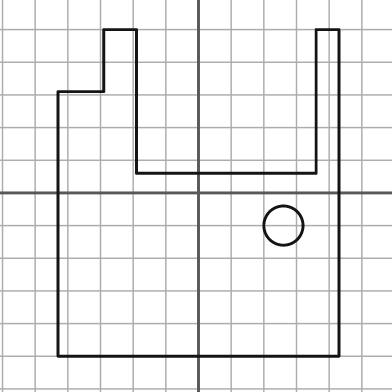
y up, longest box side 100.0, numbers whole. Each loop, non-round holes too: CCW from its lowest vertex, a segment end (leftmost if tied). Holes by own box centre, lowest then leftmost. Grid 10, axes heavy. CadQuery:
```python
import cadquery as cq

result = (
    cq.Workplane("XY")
    .moveTo(-43.0, -50.0)
    .lineTo(43.0, -50.0)
    .lineTo(43.0, 50.0)
    .lineTo(36.0, 50.0)
    .lineTo(36.0, 6.0)
    .lineTo(-19.0, 6.0)
    .lineTo(-19.0, 50.0)
    .lineTo(-29.0, 50.0)
    .lineTo(-29.0, 31.0)
    .lineTo(-43.0, 31.0)
    .close()
    .moveTo(26.0, -10.0)
    .circle(6.0)
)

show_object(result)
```